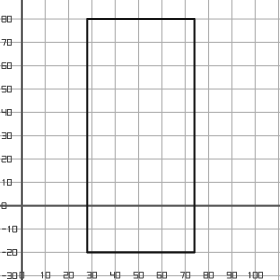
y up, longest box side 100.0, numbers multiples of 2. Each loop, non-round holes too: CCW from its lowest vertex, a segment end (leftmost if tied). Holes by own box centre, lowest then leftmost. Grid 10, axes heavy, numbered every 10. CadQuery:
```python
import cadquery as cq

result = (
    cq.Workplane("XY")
    .moveTo(28.0, -20.0)
    .lineTo(74.0, -20.0)
    .lineTo(74.0, 80.0)
    .lineTo(28.0, 80.0)
    .close()
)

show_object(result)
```